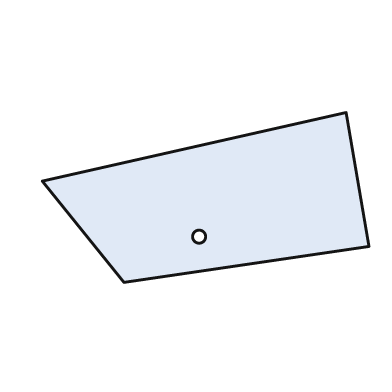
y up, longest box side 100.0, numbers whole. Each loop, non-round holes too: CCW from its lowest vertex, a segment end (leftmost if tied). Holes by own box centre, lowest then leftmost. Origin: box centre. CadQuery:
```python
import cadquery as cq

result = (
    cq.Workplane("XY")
    .moveTo(-25.0, -26.0)
    .lineTo(50.0, -15.0)
    .lineTo(43.0, 26.0)
    .lineTo(-50.0, 5.0)
    .close()
    .moveTo(-2.0, -12.0)
    .circle(2.0)
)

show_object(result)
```